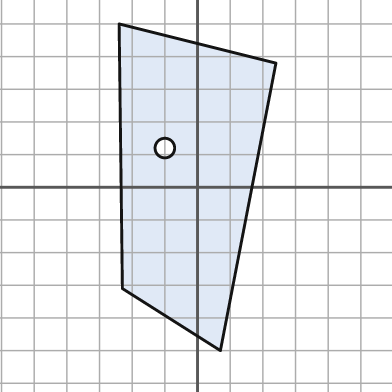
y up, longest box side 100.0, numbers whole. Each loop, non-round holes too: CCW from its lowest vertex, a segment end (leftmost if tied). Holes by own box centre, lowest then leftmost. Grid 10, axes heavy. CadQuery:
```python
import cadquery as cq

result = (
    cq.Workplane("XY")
    .moveTo(7.0, -50.0)
    .lineTo(24.0, 38.0)
    .lineTo(-24.0, 50.0)
    .lineTo(-23.0, -31.0)
    .close()
    .moveTo(-10.0, 12.0)
    .circle(3.0)
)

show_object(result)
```